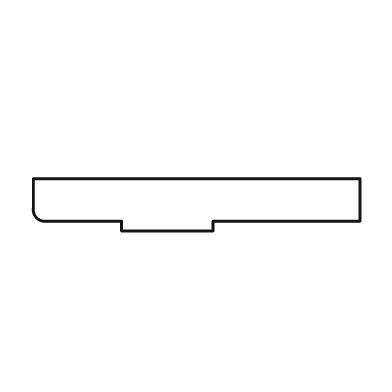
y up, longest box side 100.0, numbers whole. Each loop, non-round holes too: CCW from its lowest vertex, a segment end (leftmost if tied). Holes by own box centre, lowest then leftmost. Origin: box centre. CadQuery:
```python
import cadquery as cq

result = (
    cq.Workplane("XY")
    .moveTo(-23.0, -8.0)
    .lineTo(5.0, -8.0)
    .lineTo(5.0, -5.0)
    .lineTo(50.0, -5.0)
    .lineTo(50.0, 8.0)
    .lineTo(-50.0, 8.0)
    .lineTo(-50.0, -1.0)
    .threePointArc((-49.0, -4.0), (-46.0, -5.0))
    .lineTo(-23.0, -5.0)
    .close()
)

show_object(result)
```